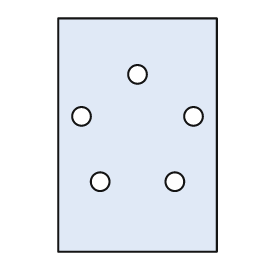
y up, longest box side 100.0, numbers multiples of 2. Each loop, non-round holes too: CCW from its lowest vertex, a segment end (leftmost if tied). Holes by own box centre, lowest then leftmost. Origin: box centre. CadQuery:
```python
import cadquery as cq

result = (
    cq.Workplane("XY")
    .moveTo(-34.0, -50.0)
    .lineTo(34.0, -50.0)
    .lineTo(34.0, 50.0)
    .lineTo(-34.0, 50.0)
    .close()
    .moveTo(-16.0, -20.0)
    .circle(4.0)
    .moveTo(16.0, -20.0)
    .circle(4.0)
    .moveTo(-24.0, 8.0)
    .circle(4.0)
    .moveTo(24.0, 8.0)
    .circle(4.0)
    .moveTo(0.0, 26.0)
    .circle(4.0)
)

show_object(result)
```